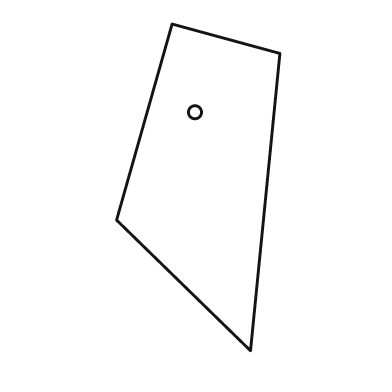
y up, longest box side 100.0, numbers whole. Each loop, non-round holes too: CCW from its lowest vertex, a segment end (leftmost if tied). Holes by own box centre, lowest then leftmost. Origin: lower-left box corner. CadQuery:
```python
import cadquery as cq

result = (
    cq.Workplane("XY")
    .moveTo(41.0, 0.0)
    .lineTo(50.0, 91.0)
    .lineTo(17.0, 100.0)
    .lineTo(0.0, 40.0)
    .close()
    .moveTo(24.0, 73.0)
    .circle(2.0)
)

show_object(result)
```